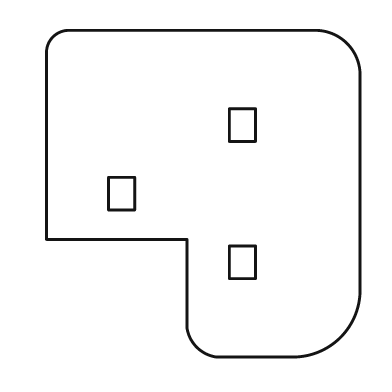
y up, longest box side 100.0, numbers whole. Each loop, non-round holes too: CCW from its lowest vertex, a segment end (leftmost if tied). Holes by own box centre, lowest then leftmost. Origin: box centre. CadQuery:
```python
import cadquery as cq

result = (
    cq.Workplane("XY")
    .moveTo(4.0, -50.0)
    .lineTo(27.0, -50.0)
    .threePointArc((42.0, -44.0), (48.0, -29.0))
    .lineTo(48.0, 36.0)
    .threePointArc((44.0, 46.0), (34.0, 50.0))
    .lineTo(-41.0, 50.0)
    .threePointArc((-46.0, 48.0), (-48.0, 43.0))
    .lineTo(-48.0, -14.0)
    .lineTo(-5.0, -14.0)
    .lineTo(-5.0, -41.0)
    .threePointArc((-2.0, -47.0), (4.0, -50.0))
    .close()
    .moveTo(8.0, -26.0)
    .lineTo(16.0, -26.0)
    .lineTo(16.0, -16.0)
    .lineTo(8.0, -16.0)
    .close()
    .moveTo(-29.0, -5.0)
    .lineTo(-21.0, -5.0)
    .lineTo(-21.0, 5.0)
    .lineTo(-29.0, 5.0)
    .close()
    .moveTo(8.0, 16.0)
    .lineTo(16.0, 16.0)
    .lineTo(16.0, 26.0)
    .lineTo(8.0, 26.0)
    .close()
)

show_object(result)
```